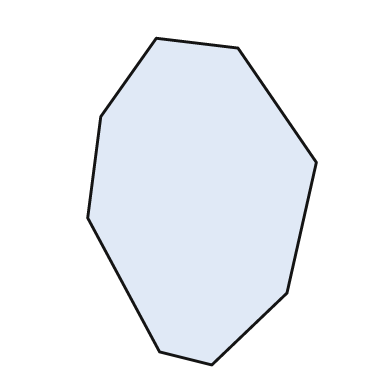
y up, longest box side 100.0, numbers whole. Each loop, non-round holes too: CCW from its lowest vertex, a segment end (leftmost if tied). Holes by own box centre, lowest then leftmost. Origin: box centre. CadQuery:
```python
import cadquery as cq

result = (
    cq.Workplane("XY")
    .moveTo(3.0, -50.0)
    .lineTo(26.0, -28.0)
    .lineTo(35.0, 12.0)
    .lineTo(11.0, 47.0)
    .lineTo(-14.0, 50.0)
    .lineTo(-31.0, 26.0)
    .lineTo(-35.0, -5.0)
    .lineTo(-13.0, -46.0)
    .close()
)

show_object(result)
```